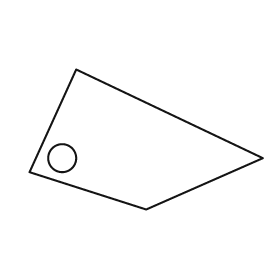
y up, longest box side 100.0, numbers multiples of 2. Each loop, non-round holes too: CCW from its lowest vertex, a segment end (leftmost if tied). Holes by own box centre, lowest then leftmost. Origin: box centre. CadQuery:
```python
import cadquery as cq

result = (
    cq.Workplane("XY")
    .moveTo(0.0, -30.0)
    .lineTo(50.0, -8.0)
    .lineTo(-30.0, 30.0)
    .lineTo(-50.0, -14.0)
    .close()
    .moveTo(-36.0, -8.0)
    .circle(6.0)
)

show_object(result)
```